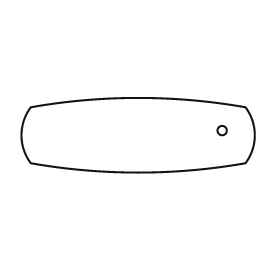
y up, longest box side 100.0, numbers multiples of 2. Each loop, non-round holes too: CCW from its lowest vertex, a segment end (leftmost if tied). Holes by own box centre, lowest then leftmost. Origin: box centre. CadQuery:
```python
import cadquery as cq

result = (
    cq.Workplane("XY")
    .moveTo(-46.0, -12.0)
    .threePointArc((0.0, -16.0), (46.0, -12.0))
    .threePointArc((50.0, 0.0), (46.0, 12.0))
    .threePointArc((0.0, 16.0), (-46.0, 12.0))
    .threePointArc((-50.0, 0.0), (-46.0, -12.0))
    .close()
    .moveTo(36.0, 2.0)
    .circle(2.0)
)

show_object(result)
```